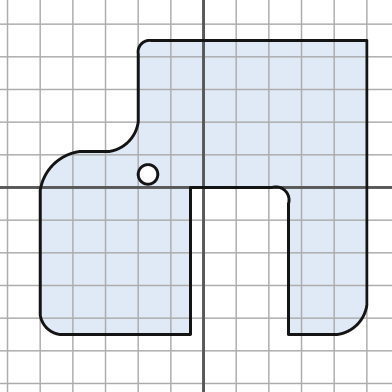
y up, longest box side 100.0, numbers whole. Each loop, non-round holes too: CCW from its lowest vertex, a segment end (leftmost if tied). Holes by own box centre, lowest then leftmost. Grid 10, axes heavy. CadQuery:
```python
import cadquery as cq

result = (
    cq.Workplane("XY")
    .moveTo(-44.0, -45.0)
    .lineTo(-4.0, -45.0)
    .lineTo(-4.0, 0.0)
    .lineTo(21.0, 0.0)
    .threePointArc((25.0, -1.0), (26.0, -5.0))
    .lineTo(26.0, -45.0)
    .lineTo(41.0, -45.0)
    .threePointArc((47.0, -42.0), (50.0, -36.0))
    .lineTo(50.0, 45.0)
    .lineTo(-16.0, 45.0)
    .threePointArc((-19.0, 44.0), (-20.0, 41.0))
    .lineTo(-20.0, 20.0)
    .threePointArc((-23.0, 14.0), (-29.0, 11.0))
    .lineTo(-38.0, 11.0)
    .threePointArc((-46.0, 7.0), (-50.0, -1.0))
    .lineTo(-50.0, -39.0)
    .threePointArc((-48.0, -43.0), (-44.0, -45.0))
    .close()
    .moveTo(-17.0, 4.0)
    .circle(3.0)
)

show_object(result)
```